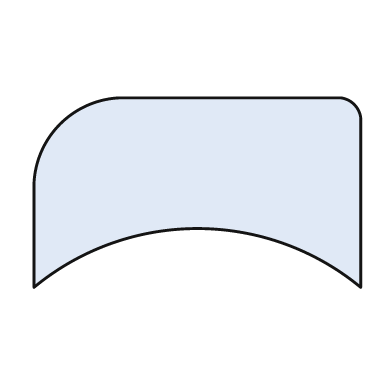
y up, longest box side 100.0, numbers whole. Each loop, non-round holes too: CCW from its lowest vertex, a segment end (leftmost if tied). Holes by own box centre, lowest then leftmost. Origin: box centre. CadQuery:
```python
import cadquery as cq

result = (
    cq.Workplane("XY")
    .moveTo(-50.0, -29.0)
    .threePointArc((0.0, -11.0), (50.0, -29.0))
    .lineTo(50.0, 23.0)
    .threePointArc((48.0, 27.0), (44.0, 29.0))
    .lineTo(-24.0, 29.0)
    .threePointArc((-42.0, 21.0), (-50.0, 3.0))
    .close()
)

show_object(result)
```